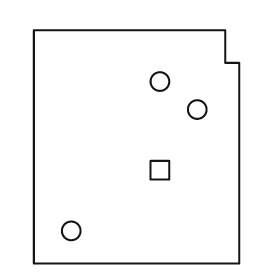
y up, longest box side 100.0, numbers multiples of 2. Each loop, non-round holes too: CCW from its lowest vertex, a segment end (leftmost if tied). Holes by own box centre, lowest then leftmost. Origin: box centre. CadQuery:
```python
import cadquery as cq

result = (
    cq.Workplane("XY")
    .moveTo(-44.0, -50.0)
    .lineTo(44.0, -50.0)
    .lineTo(44.0, 36.0)
    .lineTo(38.0, 36.0)
    .lineTo(38.0, 50.0)
    .lineTo(-44.0, 50.0)
    .close()
    .moveTo(-28.0, -36.0)
    .circle(4.0)
    .moveTo(6.0, -14.0)
    .lineTo(14.0, -14.0)
    .lineTo(14.0, -6.0)
    .lineTo(6.0, -6.0)
    .close()
    .moveTo(26.0, 16.0)
    .circle(4.0)
    .moveTo(10.0, 28.0)
    .circle(4.0)
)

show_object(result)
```